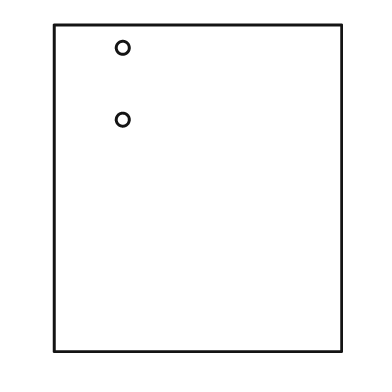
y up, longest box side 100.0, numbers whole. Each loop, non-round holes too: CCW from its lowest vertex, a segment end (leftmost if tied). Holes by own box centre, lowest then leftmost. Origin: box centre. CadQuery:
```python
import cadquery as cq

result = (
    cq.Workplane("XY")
    .moveTo(-44.0, -50.0)
    .lineTo(44.0, -50.0)
    .lineTo(44.0, 50.0)
    .lineTo(-44.0, 50.0)
    .close()
    .moveTo(-23.0, 21.0)
    .circle(2.0)
    .moveTo(-23.0, 43.0)
    .circle(2.0)
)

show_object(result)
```